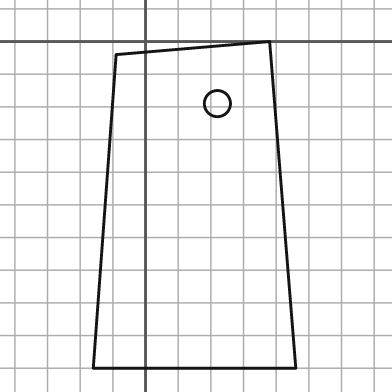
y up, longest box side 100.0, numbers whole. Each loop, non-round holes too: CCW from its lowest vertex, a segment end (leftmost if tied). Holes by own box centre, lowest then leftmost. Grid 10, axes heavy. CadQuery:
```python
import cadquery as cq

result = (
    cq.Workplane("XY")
    .moveTo(-16.0, -100.0)
    .lineTo(46.0, -100.0)
    .lineTo(38.0, 0.0)
    .lineTo(-9.0, -4.0)
    .close()
    .moveTo(22.0, -19.0)
    .circle(4.0)
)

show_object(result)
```